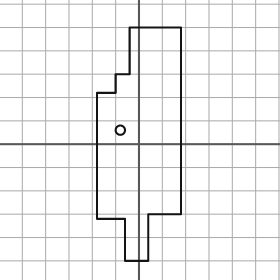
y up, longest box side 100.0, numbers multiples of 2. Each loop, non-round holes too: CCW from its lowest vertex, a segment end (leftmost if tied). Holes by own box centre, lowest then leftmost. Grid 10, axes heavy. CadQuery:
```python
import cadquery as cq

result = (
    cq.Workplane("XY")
    .moveTo(-6.0, -50.0)
    .lineTo(4.0, -50.0)
    .lineTo(4.0, -30.0)
    .lineTo(18.0, -30.0)
    .lineTo(18.0, 50.0)
    .lineTo(-4.0, 50.0)
    .lineTo(-4.0, 30.0)
    .lineTo(-10.0, 30.0)
    .lineTo(-10.0, 22.0)
    .lineTo(-18.0, 22.0)
    .lineTo(-18.0, -32.0)
    .lineTo(-6.0, -32.0)
    .close()
    .moveTo(-8.0, 6.0)
    .circle(2.0)
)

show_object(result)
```